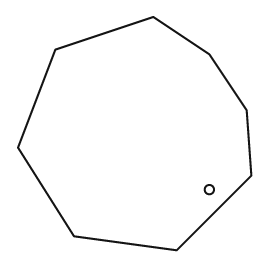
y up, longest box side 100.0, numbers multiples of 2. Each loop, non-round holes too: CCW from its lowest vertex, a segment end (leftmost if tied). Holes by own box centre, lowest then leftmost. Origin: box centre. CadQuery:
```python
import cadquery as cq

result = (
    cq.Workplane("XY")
    .moveTo(18.0, -50.0)
    .lineTo(50.0, -18.0)
    .lineTo(48.0, 10.0)
    .lineTo(32.0, 34.0)
    .lineTo(8.0, 50.0)
    .lineTo(-34.0, 36.0)
    .lineTo(-50.0, -6.0)
    .lineTo(-26.0, -44.0)
    .close()
    .moveTo(32.0, -24.0)
    .circle(2.0)
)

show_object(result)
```